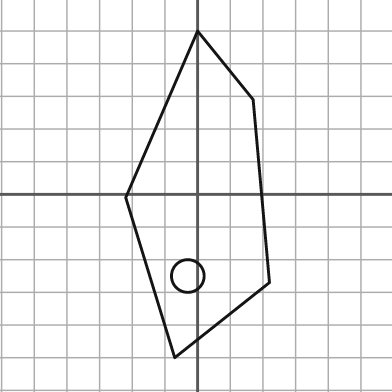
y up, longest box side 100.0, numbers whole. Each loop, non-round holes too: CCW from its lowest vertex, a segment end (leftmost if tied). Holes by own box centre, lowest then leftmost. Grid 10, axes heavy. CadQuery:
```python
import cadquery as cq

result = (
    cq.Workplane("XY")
    .moveTo(-7.0, -50.0)
    .lineTo(22.0, -27.0)
    .lineTo(17.0, 29.0)
    .lineTo(0.0, 50.0)
    .lineTo(-22.0, -1.0)
    .close()
    .moveTo(-3.0, -25.0)
    .circle(5.0)
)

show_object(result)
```